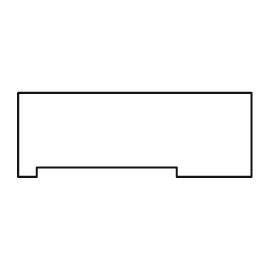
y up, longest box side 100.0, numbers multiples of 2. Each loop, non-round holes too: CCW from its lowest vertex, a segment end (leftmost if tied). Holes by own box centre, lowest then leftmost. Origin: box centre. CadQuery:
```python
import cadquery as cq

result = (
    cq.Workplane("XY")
    .moveTo(-50.0, -18.0)
    .lineTo(-42.0, -18.0)
    .lineTo(-42.0, -14.0)
    .lineTo(18.0, -14.0)
    .lineTo(18.0, -18.0)
    .lineTo(50.0, -18.0)
    .lineTo(50.0, 18.0)
    .lineTo(-50.0, 18.0)
    .close()
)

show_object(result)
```